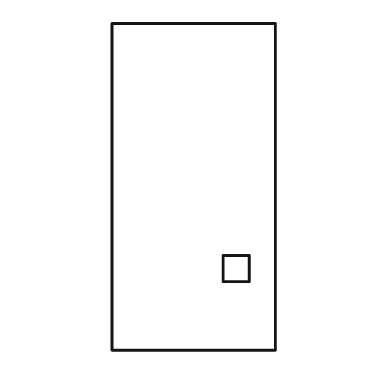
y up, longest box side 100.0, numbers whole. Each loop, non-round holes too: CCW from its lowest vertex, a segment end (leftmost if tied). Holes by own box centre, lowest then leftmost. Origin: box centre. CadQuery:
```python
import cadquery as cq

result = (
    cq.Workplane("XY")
    .moveTo(-25.0, -50.0)
    .lineTo(25.0, -50.0)
    .lineTo(25.0, 50.0)
    .lineTo(-25.0, 50.0)
    .close()
    .moveTo(9.0, -29.0)
    .lineTo(17.0, -29.0)
    .lineTo(17.0, -21.0)
    .lineTo(9.0, -21.0)
    .close()
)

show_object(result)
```